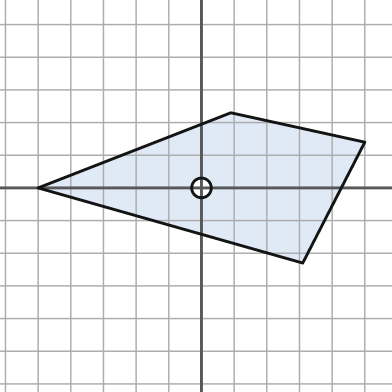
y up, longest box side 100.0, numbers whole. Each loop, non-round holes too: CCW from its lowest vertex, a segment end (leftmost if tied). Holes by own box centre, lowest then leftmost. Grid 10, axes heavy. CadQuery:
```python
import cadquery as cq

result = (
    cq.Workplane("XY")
    .moveTo(31.0, -23.0)
    .lineTo(50.0, 14.0)
    .lineTo(9.0, 23.0)
    .lineTo(-50.0, 0.0)
    .close()
    .moveTo(0.0, 0.0)
    .circle(3.0)
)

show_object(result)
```